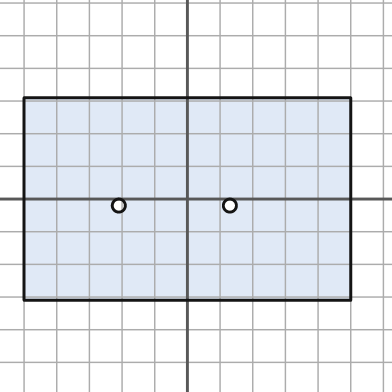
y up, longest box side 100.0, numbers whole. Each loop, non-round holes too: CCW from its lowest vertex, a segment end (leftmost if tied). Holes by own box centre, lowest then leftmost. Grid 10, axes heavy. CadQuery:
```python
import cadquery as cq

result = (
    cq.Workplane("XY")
    .moveTo(-50.0, -31.0)
    .lineTo(50.0, -31.0)
    .lineTo(50.0, 31.0)
    .lineTo(-50.0, 31.0)
    .close()
    .moveTo(-21.0, -2.0)
    .circle(2.0)
    .moveTo(13.0, -2.0)
    .circle(2.0)
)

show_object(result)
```